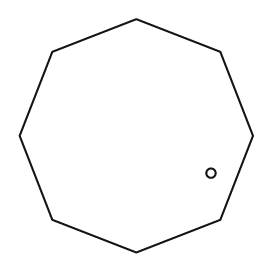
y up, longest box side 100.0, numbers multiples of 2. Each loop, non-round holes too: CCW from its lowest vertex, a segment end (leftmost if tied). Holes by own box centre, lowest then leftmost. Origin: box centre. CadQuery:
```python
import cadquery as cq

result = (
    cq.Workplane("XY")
    .moveTo(0.0, -50.0)
    .lineTo(36.0, -36.0)
    .lineTo(50.0, 0.0)
    .lineTo(36.0, 36.0)
    .lineTo(0.0, 50.0)
    .lineTo(-36.0, 36.0)
    .lineTo(-50.0, 0.0)
    .lineTo(-36.0, -36.0)
    .close()
    .moveTo(32.0, -16.0)
    .circle(2.0)
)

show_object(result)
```